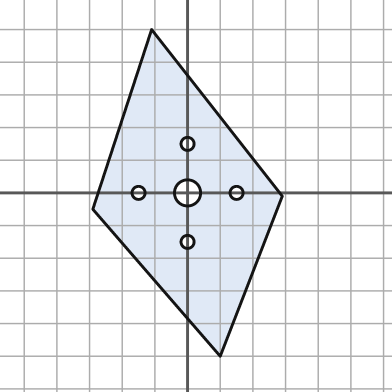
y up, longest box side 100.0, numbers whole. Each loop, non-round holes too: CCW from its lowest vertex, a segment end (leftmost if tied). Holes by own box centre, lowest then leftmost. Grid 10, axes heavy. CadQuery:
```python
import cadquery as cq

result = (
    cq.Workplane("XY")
    .moveTo(10.0, -50.0)
    .lineTo(29.0, -1.0)
    .lineTo(-11.0, 50.0)
    .lineTo(-29.0, -5.0)
    .close()
    .moveTo(0.0, -15.0)
    .circle(2.0)
    .moveTo(-15.0, 0.0)
    .circle(2.0)
    .moveTo(0.0, 0.0)
    .circle(4.0)
    .moveTo(15.0, 0.0)
    .circle(2.0)
    .moveTo(0.0, 15.0)
    .circle(2.0)
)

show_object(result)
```